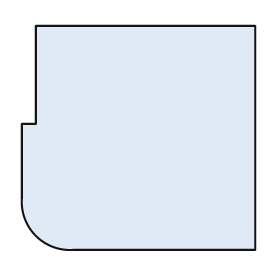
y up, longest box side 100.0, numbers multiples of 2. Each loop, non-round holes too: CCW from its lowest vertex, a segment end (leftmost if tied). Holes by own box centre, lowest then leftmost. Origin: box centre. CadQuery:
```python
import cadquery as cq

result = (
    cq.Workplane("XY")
    .moveTo(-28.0, -48.0)
    .lineTo(50.0, -48.0)
    .lineTo(50.0, 48.0)
    .lineTo(-44.0, 48.0)
    .lineTo(-44.0, 6.0)
    .lineTo(-50.0, 6.0)
    .lineTo(-50.0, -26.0)
    .threePointArc((-44.0, -42.0), (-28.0, -48.0))
    .close()
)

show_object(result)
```